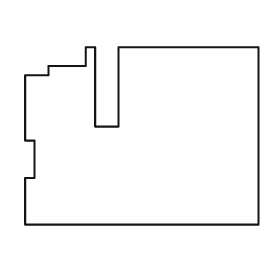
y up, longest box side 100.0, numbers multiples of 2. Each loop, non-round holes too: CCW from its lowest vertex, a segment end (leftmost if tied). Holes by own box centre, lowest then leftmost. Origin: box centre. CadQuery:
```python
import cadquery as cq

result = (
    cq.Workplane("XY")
    .moveTo(-50.0, -38.0)
    .lineTo(50.0, -38.0)
    .lineTo(50.0, 38.0)
    .lineTo(-10.0, 38.0)
    .lineTo(-10.0, 4.0)
    .lineTo(-20.0, 4.0)
    .lineTo(-20.0, 38.0)
    .lineTo(-24.0, 38.0)
    .lineTo(-24.0, 30.0)
    .lineTo(-40.0, 30.0)
    .lineTo(-40.0, 26.0)
    .lineTo(-50.0, 26.0)
    .lineTo(-50.0, -2.0)
    .lineTo(-46.0, -2.0)
    .lineTo(-46.0, -18.0)
    .lineTo(-50.0, -18.0)
    .close()
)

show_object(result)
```